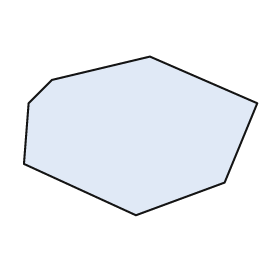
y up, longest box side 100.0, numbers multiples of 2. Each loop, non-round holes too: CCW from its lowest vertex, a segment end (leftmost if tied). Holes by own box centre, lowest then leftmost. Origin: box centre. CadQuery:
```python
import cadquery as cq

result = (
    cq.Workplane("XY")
    .moveTo(-2.0, -34.0)
    .lineTo(36.0, -20.0)
    .lineTo(50.0, 14.0)
    .lineTo(4.0, 34.0)
    .lineTo(-38.0, 24.0)
    .lineTo(-48.0, 14.0)
    .lineTo(-50.0, -12.0)
    .close()
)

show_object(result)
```